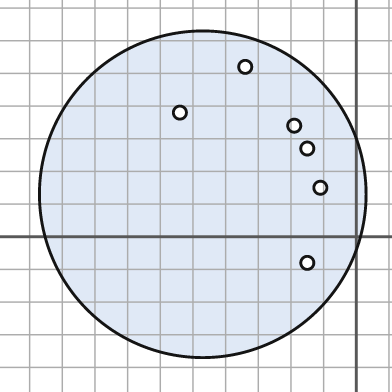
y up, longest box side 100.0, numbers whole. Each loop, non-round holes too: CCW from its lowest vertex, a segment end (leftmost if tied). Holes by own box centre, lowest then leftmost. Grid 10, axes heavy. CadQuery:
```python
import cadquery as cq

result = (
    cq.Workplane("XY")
    .moveTo(-47.0, 13.0)
    .circle(50.0)
    .moveTo(-15.0, -8.0)
    .circle(2.0)
    .moveTo(-11.0, 15.0)
    .circle(2.0)
    .moveTo(-15.0, 27.0)
    .circle(2.0)
    .moveTo(-19.0, 34.0)
    .circle(2.0)
    .moveTo(-54.0, 38.0)
    .circle(2.0)
    .moveTo(-34.0, 52.0)
    .circle(2.0)
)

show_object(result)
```